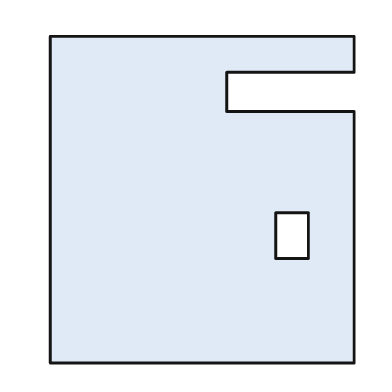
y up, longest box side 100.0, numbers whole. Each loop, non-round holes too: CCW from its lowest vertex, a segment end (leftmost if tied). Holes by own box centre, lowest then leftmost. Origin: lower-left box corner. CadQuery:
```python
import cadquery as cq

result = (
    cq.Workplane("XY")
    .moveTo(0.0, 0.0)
    .lineTo(93.0, 0.0)
    .lineTo(93.0, 77.0)
    .lineTo(54.0, 77.0)
    .lineTo(54.0, 89.0)
    .lineTo(93.0, 89.0)
    .lineTo(93.0, 100.0)
    .lineTo(0.0, 100.0)
    .close()
    .moveTo(69.0, 32.0)
    .lineTo(79.0, 32.0)
    .lineTo(79.0, 46.0)
    .lineTo(69.0, 46.0)
    .close()
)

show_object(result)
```